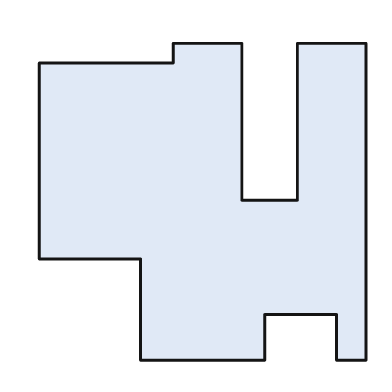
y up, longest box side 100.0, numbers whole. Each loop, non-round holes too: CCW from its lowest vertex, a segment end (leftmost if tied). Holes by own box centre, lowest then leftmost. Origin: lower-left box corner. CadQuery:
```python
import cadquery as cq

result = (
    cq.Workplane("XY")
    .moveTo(31.0, 0.0)
    .lineTo(69.0, 0.0)
    .lineTo(69.0, 14.0)
    .lineTo(91.0, 14.0)
    .lineTo(91.0, 0.0)
    .lineTo(100.0, 0.0)
    .lineTo(100.0, 97.0)
    .lineTo(79.0, 97.0)
    .lineTo(79.0, 49.0)
    .lineTo(62.0, 49.0)
    .lineTo(62.0, 97.0)
    .lineTo(41.0, 97.0)
    .lineTo(41.0, 91.0)
    .lineTo(0.0, 91.0)
    .lineTo(0.0, 31.0)
    .lineTo(31.0, 31.0)
    .close()
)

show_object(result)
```